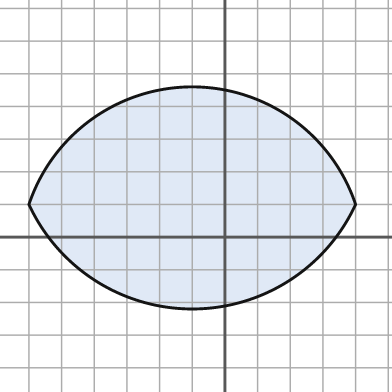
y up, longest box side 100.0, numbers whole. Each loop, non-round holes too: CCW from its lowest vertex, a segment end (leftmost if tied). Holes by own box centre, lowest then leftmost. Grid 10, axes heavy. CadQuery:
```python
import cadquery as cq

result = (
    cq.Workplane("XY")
    .moveTo(-60.0, 10.0)
    .threePointArc((-10.0, -22.0), (40.0, 10.0))
    .threePointArc((-10.0, 46.0), (-60.0, 10.0))
    .close()
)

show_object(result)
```